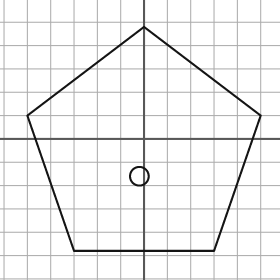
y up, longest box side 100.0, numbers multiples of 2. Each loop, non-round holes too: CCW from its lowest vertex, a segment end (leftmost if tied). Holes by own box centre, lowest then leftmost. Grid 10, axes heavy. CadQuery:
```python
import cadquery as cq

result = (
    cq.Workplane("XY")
    .moveTo(-30.0, -48.0)
    .lineTo(30.0, -48.0)
    .lineTo(50.0, 10.0)
    .lineTo(0.0, 48.0)
    .lineTo(-50.0, 10.0)
    .close()
    .moveTo(-2.0, -16.0)
    .circle(4.0)
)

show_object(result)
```